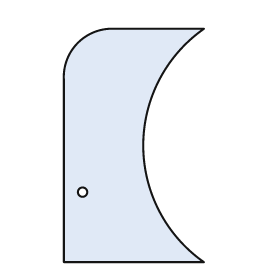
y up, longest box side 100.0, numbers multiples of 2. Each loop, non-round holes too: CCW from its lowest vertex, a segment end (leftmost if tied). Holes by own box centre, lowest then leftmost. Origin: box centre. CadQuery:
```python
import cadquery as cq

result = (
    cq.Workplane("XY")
    .moveTo(-30.0, -50.0)
    .lineTo(30.0, -50.0)
    .threePointArc((4.0, 0.0), (30.0, 50.0))
    .lineTo(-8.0, 50.0)
    .threePointArc((-24.0, 44.0), (-30.0, 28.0))
    .close()
    .moveTo(-22.0, -20.0)
    .circle(2.0)
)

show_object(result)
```